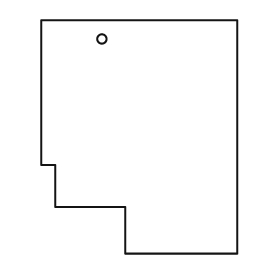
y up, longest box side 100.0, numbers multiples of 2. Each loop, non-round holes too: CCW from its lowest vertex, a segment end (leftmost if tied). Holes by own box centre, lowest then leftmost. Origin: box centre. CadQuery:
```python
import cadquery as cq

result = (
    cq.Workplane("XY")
    .moveTo(-6.0, -50.0)
    .lineTo(42.0, -50.0)
    .lineTo(42.0, 50.0)
    .lineTo(-42.0, 50.0)
    .lineTo(-42.0, -12.0)
    .lineTo(-36.0, -12.0)
    .lineTo(-36.0, -30.0)
    .lineTo(-6.0, -30.0)
    .close()
    .moveTo(-16.0, 42.0)
    .circle(2.0)
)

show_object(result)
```